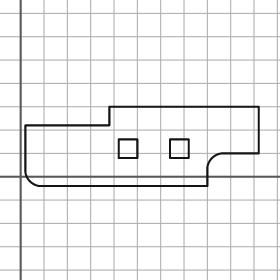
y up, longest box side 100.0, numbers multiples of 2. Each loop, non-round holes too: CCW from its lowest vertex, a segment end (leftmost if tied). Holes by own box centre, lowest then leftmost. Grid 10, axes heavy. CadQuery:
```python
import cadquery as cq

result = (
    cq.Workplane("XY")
    .moveTo(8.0, -4.0)
    .lineTo(80.0, -4.0)
    .lineTo(80.0, 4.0)
    .threePointArc((82.0, 8.0), (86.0, 10.0))
    .lineTo(102.0, 10.0)
    .lineTo(102.0, 30.0)
    .lineTo(38.0, 30.0)
    .lineTo(38.0, 22.0)
    .lineTo(2.0, 22.0)
    .lineTo(2.0, 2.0)
    .threePointArc((4.0, -2.0), (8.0, -4.0))
    .close()
    .moveTo(42.0, 8.0)
    .lineTo(50.0, 8.0)
    .lineTo(50.0, 16.0)
    .lineTo(42.0, 16.0)
    .close()
    .moveTo(64.0, 8.0)
    .lineTo(72.0, 8.0)
    .lineTo(72.0, 16.0)
    .lineTo(64.0, 16.0)
    .close()
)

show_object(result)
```